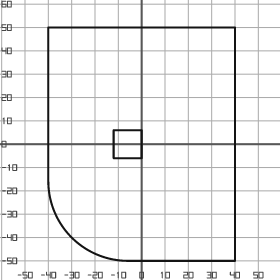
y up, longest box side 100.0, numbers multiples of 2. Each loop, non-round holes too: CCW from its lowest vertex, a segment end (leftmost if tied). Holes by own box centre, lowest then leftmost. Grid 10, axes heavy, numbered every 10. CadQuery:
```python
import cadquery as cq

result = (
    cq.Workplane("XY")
    .moveTo(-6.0, -50.0)
    .lineTo(40.0, -50.0)
    .lineTo(40.0, 50.0)
    .lineTo(-40.0, 50.0)
    .lineTo(-40.0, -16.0)
    .threePointArc((-30.0, -40.0), (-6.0, -50.0))
    .close()
    .moveTo(-12.0, -6.0)
    .lineTo(0.0, -6.0)
    .lineTo(0.0, 6.0)
    .lineTo(-12.0, 6.0)
    .close()
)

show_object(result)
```